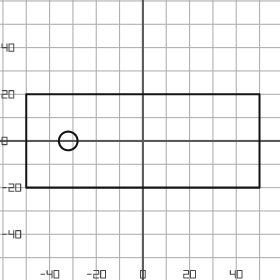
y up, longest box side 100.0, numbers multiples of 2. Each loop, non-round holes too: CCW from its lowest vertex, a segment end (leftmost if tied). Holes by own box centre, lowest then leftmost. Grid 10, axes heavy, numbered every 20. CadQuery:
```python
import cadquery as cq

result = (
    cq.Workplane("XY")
    .moveTo(-50.0, -20.0)
    .lineTo(50.0, -20.0)
    .lineTo(50.0, 20.0)
    .lineTo(-50.0, 20.0)
    .close()
    .moveTo(-32.0, 0.0)
    .circle(4.0)
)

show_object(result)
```